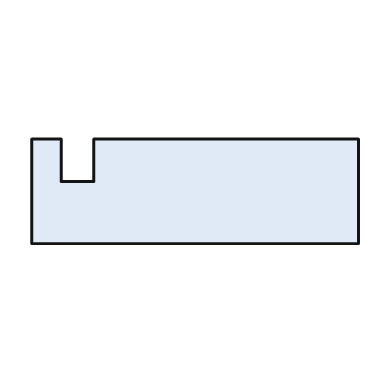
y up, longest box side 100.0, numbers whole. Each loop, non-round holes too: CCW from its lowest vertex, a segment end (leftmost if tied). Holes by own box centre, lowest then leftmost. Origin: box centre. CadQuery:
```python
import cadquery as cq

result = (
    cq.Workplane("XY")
    .moveTo(-50.0, -16.0)
    .lineTo(50.0, -16.0)
    .lineTo(50.0, 16.0)
    .lineTo(-31.0, 16.0)
    .lineTo(-31.0, 3.0)
    .lineTo(-41.0, 3.0)
    .lineTo(-41.0, 16.0)
    .lineTo(-50.0, 16.0)
    .close()
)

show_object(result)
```